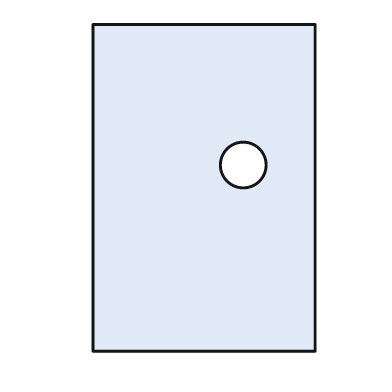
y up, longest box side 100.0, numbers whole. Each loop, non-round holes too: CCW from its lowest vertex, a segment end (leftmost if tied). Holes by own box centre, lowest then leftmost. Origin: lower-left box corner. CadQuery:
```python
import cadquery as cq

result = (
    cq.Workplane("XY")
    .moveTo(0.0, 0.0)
    .lineTo(68.0, 0.0)
    .lineTo(68.0, 100.0)
    .lineTo(0.0, 100.0)
    .close()
    .moveTo(46.0, 57.0)
    .circle(7.0)
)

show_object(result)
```